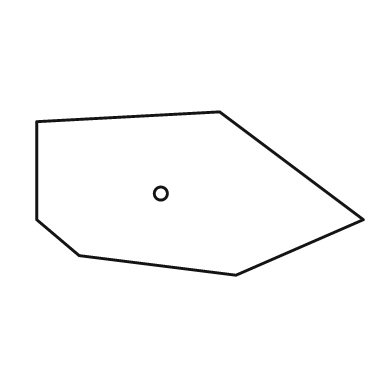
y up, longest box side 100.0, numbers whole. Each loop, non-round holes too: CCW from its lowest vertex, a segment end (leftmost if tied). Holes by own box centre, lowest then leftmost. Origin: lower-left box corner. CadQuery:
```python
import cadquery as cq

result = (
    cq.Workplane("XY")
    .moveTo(61.0, 0.0)
    .lineTo(100.0, 17.0)
    .lineTo(56.0, 50.0)
    .lineTo(0.0, 47.0)
    .lineTo(0.0, 17.0)
    .lineTo(13.0, 6.0)
    .close()
    .moveTo(38.0, 25.0)
    .circle(2.0)
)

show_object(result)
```